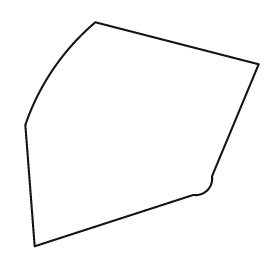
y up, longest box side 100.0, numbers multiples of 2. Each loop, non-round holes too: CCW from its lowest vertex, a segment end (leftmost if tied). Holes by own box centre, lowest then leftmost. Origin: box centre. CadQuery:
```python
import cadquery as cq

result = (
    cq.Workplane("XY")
    .moveTo(-46.0, -48.0)
    .lineTo(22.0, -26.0)
    .threePointArc((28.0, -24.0), (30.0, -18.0))
    .lineTo(50.0, 30.0)
    .lineTo(-20.0, 48.0)
    .threePointArc((-38.0, 28.0), (-50.0, 4.0))
    .close()
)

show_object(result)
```